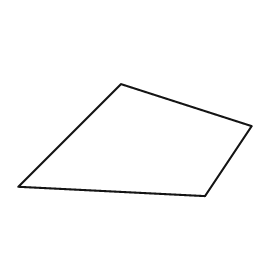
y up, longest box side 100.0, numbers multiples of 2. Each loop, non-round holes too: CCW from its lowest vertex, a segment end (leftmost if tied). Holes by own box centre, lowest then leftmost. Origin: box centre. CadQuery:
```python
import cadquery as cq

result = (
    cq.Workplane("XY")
    .moveTo(30.0, -24.0)
    .lineTo(50.0, 6.0)
    .lineTo(-6.0, 24.0)
    .lineTo(-50.0, -20.0)
    .close()
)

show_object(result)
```